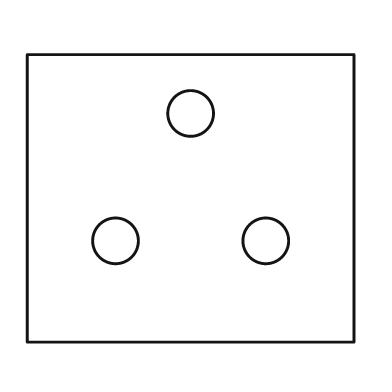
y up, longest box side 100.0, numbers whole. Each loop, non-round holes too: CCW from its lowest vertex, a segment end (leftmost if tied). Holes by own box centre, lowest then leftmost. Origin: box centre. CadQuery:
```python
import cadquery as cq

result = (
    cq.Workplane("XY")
    .moveTo(-50.0, -44.0)
    .lineTo(50.0, -44.0)
    .lineTo(50.0, 44.0)
    .lineTo(-50.0, 44.0)
    .close()
    .moveTo(-23.0, -13.0)
    .circle(7.0)
    .moveTo(23.0, -13.0)
    .circle(7.0)
    .moveTo(0.0, 26.0)
    .circle(7.0)
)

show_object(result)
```